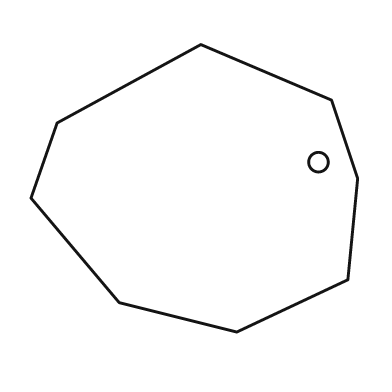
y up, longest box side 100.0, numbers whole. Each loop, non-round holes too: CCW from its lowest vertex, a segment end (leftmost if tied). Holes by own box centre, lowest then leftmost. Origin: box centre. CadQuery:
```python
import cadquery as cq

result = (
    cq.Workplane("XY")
    .moveTo(13.0, -44.0)
    .lineTo(47.0, -28.0)
    .lineTo(50.0, 3.0)
    .lineTo(42.0, 27.0)
    .lineTo(2.0, 44.0)
    .lineTo(-42.0, 20.0)
    .lineTo(-50.0, -3.0)
    .lineTo(-23.0, -35.0)
    .close()
    .moveTo(38.0, 8.0)
    .circle(3.0)
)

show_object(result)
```